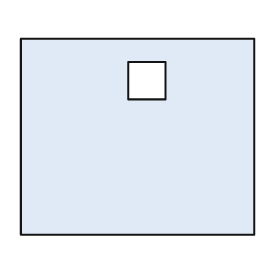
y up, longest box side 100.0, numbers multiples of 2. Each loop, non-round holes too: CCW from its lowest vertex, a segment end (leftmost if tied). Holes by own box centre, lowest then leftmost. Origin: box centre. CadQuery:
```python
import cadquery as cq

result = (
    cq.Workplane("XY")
    .moveTo(-50.0, -42.0)
    .lineTo(50.0, -42.0)
    .lineTo(50.0, 42.0)
    .lineTo(-50.0, 42.0)
    .close()
    .moveTo(-4.0, 16.0)
    .lineTo(12.0, 16.0)
    .lineTo(12.0, 32.0)
    .lineTo(-4.0, 32.0)
    .close()
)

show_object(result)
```